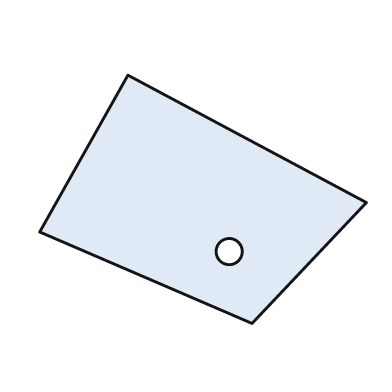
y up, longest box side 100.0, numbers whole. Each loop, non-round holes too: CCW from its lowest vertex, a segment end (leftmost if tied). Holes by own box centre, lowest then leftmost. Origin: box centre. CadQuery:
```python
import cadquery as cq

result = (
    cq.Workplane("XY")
    .moveTo(15.0, -38.0)
    .lineTo(50.0, -1.0)
    .lineTo(-23.0, 38.0)
    .lineTo(-50.0, -10.0)
    .close()
    .moveTo(8.0, -16.0)
    .circle(4.0)
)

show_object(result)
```